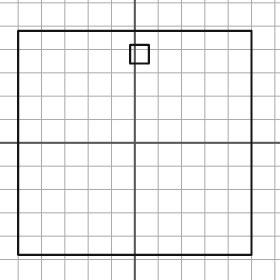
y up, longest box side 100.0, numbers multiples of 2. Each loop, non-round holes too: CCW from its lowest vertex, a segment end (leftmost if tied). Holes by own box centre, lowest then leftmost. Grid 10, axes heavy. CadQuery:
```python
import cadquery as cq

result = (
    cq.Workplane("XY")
    .moveTo(-50.0, -48.0)
    .lineTo(50.0, -48.0)
    .lineTo(50.0, 48.0)
    .lineTo(-50.0, 48.0)
    .close()
    .moveTo(-2.0, 34.0)
    .lineTo(6.0, 34.0)
    .lineTo(6.0, 42.0)
    .lineTo(-2.0, 42.0)
    .close()
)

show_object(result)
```